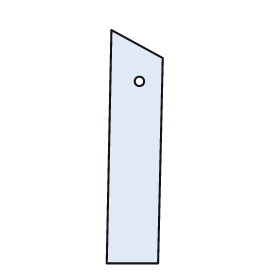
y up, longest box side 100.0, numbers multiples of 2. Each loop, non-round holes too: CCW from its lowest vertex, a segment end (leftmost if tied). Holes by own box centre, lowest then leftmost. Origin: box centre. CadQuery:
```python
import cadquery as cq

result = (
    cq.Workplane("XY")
    .moveTo(-12.0, -50.0)
    .lineTo(10.0, -50.0)
    .lineTo(12.0, 38.0)
    .lineTo(-10.0, 50.0)
    .close()
    .moveTo(2.0, 28.0)
    .circle(2.0)
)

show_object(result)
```